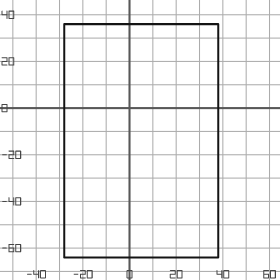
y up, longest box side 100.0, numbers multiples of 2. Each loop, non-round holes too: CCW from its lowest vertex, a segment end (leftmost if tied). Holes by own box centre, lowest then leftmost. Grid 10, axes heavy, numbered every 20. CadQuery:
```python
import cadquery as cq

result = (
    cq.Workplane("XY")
    .moveTo(-28.0, -64.0)
    .lineTo(38.0, -64.0)
    .lineTo(38.0, 36.0)
    .lineTo(-28.0, 36.0)
    .close()
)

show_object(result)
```